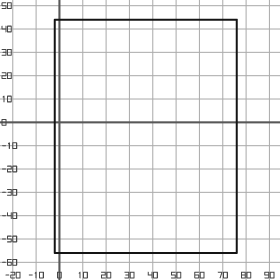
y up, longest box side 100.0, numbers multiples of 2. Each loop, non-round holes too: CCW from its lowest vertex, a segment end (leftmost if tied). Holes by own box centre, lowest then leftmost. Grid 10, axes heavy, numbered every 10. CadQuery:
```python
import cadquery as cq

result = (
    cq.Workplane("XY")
    .moveTo(-2.0, -56.0)
    .lineTo(76.0, -56.0)
    .lineTo(76.0, 44.0)
    .lineTo(-2.0, 44.0)
    .close()
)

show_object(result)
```